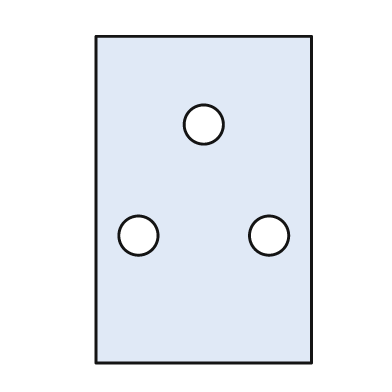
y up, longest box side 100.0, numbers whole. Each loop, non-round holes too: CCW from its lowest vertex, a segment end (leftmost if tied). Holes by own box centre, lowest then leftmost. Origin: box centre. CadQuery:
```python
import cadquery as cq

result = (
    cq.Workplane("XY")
    .moveTo(-33.0, -50.0)
    .lineTo(33.0, -50.0)
    .lineTo(33.0, 50.0)
    .lineTo(-33.0, 50.0)
    .close()
    .moveTo(-20.0, -11.0)
    .circle(6.0)
    .moveTo(20.0, -11.0)
    .circle(6.0)
    .moveTo(0.0, 23.0)
    .circle(6.0)
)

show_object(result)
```